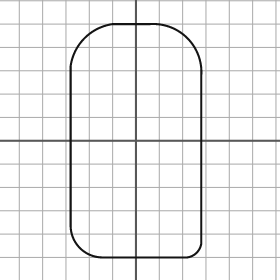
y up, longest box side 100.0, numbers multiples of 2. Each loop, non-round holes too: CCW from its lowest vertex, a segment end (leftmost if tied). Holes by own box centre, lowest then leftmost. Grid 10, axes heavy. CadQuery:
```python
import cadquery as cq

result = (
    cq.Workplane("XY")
    .moveTo(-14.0, -50.0)
    .lineTo(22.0, -50.0)
    .threePointArc((26.0, -48.0), (28.0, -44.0))
    .lineTo(28.0, 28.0)
    .threePointArc((22.0, 44.0), (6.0, 50.0))
    .lineTo(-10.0, 50.0)
    .threePointArc((-22.0, 44.0), (-28.0, 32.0))
    .lineTo(-28.0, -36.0)
    .threePointArc((-24.0, -46.0), (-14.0, -50.0))
    .close()
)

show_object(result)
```